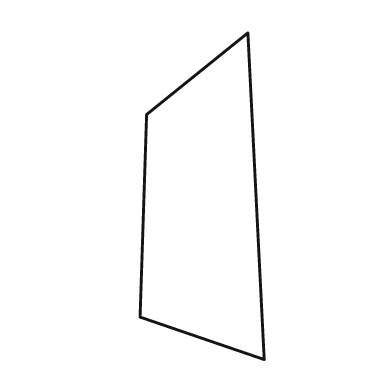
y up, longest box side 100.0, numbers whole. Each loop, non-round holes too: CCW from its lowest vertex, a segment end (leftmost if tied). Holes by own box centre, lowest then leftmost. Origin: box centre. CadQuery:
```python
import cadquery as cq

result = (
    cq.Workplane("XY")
    .moveTo(19.0, -50.0)
    .lineTo(14.0, 50.0)
    .lineTo(-17.0, 25.0)
    .lineTo(-19.0, -37.0)
    .close()
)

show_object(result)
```